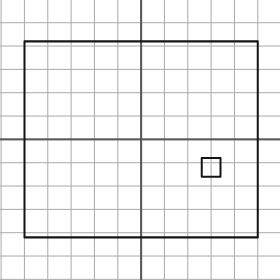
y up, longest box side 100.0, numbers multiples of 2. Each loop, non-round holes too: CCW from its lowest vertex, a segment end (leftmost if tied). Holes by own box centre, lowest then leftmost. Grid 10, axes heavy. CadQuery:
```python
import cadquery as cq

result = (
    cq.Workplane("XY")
    .moveTo(-50.0, -42.0)
    .lineTo(50.0, -42.0)
    .lineTo(50.0, 42.0)
    .lineTo(-50.0, 42.0)
    .close()
    .moveTo(26.0, -16.0)
    .lineTo(34.0, -16.0)
    .lineTo(34.0, -8.0)
    .lineTo(26.0, -8.0)
    .close()
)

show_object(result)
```